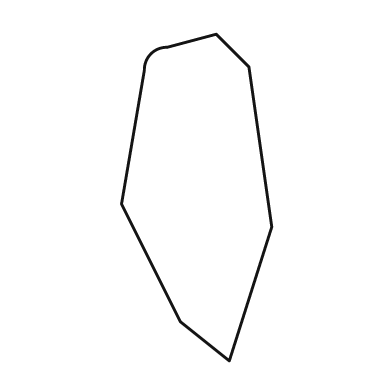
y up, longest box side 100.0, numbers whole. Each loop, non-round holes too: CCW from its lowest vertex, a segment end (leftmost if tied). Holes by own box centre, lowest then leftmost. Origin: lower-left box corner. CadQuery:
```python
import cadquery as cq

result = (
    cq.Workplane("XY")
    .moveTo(33.0, 0.0)
    .lineTo(46.0, 41.0)
    .lineTo(39.0, 90.0)
    .lineTo(29.0, 100.0)
    .lineTo(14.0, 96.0)
    .threePointArc((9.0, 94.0), (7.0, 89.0))
    .lineTo(0.0, 48.0)
    .lineTo(18.0, 12.0)
    .close()
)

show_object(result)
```